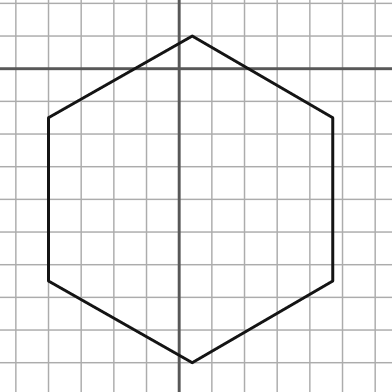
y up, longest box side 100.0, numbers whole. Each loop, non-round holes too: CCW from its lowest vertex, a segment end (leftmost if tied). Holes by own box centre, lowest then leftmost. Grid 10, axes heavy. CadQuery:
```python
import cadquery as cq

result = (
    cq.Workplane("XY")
    .moveTo(4.0, -90.0)
    .lineTo(47.0, -65.0)
    .lineTo(47.0, -15.0)
    .lineTo(4.0, 10.0)
    .lineTo(-40.0, -15.0)
    .lineTo(-40.0, -65.0)
    .close()
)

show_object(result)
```